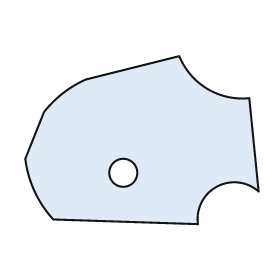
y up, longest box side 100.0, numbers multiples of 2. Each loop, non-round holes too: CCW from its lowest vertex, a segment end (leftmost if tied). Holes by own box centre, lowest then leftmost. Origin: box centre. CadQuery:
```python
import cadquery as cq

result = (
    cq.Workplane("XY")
    .moveTo(24.0, -36.0)
    .threePointArc((32.0, -20.0), (50.0, -22.0))
    .lineTo(46.0, 18.0)
    .threePointArc((28.0, 22.0), (16.0, 36.0))
    .lineTo(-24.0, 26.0)
    .threePointArc((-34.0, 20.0), (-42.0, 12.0))
    .lineTo(-50.0, -8.0)
    .threePointArc((-46.0, -22.0), (-38.0, -34.0))
    .close()
    .moveTo(-8.0, -14.0)
    .circle(6.0)
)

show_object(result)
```